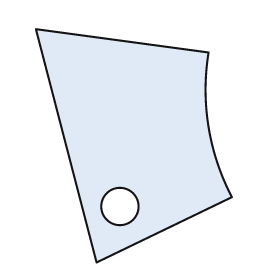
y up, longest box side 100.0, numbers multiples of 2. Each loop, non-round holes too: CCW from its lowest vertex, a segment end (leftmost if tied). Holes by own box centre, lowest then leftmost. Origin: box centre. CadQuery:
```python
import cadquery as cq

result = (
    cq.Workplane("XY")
    .moveTo(-16.0, -50.0)
    .lineTo(42.0, -22.0)
    .threePointArc((32.0, 8.0), (32.0, 40.0))
    .lineTo(-42.0, 50.0)
    .close()
    .moveTo(-6.0, -26.0)
    .circle(8.0)
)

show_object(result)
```